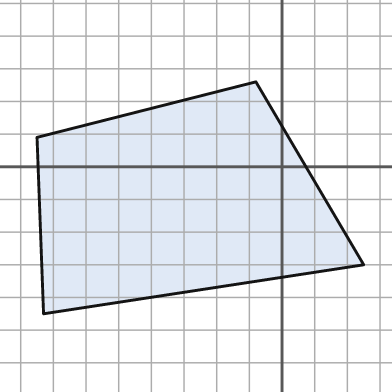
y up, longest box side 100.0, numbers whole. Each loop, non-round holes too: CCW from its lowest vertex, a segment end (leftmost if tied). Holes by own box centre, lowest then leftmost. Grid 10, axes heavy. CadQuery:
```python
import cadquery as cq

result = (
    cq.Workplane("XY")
    .moveTo(-73.0, -45.0)
    .lineTo(25.0, -30.0)
    .lineTo(-8.0, 26.0)
    .lineTo(-75.0, 9.0)
    .close()
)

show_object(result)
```